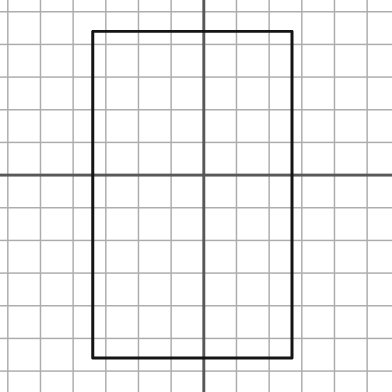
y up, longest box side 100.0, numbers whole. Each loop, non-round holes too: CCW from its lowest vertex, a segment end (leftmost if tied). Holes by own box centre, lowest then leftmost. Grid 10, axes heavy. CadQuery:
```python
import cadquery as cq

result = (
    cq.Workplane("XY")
    .moveTo(-34.0, -56.0)
    .lineTo(27.0, -56.0)
    .lineTo(27.0, 44.0)
    .lineTo(-34.0, 44.0)
    .close()
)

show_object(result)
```